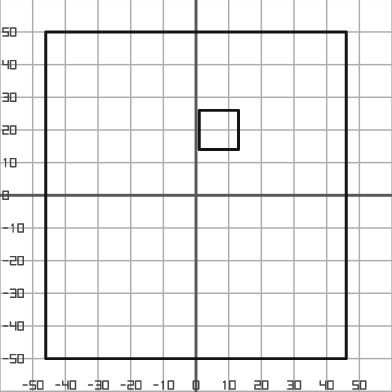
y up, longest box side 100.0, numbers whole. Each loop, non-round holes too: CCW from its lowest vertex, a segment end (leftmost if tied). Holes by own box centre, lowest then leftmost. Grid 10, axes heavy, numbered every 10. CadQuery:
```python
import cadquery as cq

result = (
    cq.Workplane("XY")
    .moveTo(-46.0, -50.0)
    .lineTo(46.0, -50.0)
    .lineTo(46.0, 50.0)
    .lineTo(-46.0, 50.0)
    .close()
    .moveTo(1.0, 14.0)
    .lineTo(13.0, 14.0)
    .lineTo(13.0, 26.0)
    .lineTo(1.0, 26.0)
    .close()
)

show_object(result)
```